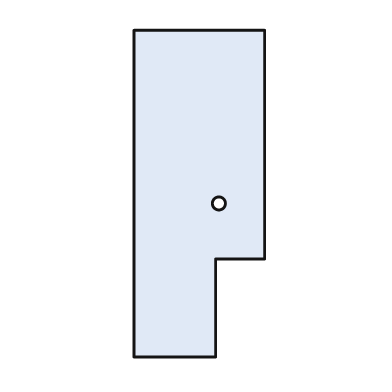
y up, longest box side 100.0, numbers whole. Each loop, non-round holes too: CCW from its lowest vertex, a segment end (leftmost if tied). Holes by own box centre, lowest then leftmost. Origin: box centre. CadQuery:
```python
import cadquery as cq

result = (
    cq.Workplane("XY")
    .moveTo(-20.0, -50.0)
    .lineTo(5.0, -50.0)
    .lineTo(5.0, -20.0)
    .lineTo(20.0, -20.0)
    .lineTo(20.0, 50.0)
    .lineTo(-20.0, 50.0)
    .close()
    .moveTo(6.0, -3.0)
    .circle(2.0)
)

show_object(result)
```